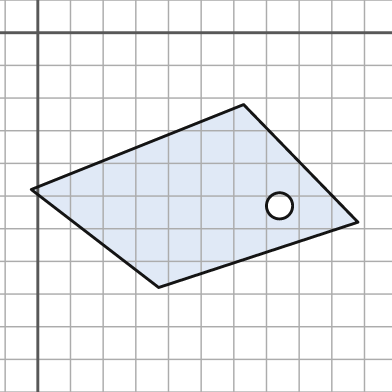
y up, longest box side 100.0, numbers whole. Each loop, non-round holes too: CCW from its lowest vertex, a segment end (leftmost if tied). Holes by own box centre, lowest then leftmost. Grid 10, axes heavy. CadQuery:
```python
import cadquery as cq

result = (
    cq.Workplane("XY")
    .moveTo(37.0, -78.0)
    .lineTo(98.0, -58.0)
    .lineTo(63.0, -22.0)
    .lineTo(-2.0, -48.0)
    .close()
    .moveTo(74.0, -53.0)
    .circle(4.0)
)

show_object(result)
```